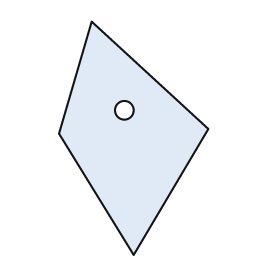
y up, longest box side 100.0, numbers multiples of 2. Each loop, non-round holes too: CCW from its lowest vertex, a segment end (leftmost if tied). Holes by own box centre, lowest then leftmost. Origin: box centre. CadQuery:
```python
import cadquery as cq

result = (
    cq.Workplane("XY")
    .moveTo(0.0, -50.0)
    .lineTo(32.0, 4.0)
    .lineTo(-18.0, 50.0)
    .lineTo(-32.0, 2.0)
    .close()
    .moveTo(-4.0, 12.0)
    .circle(4.0)
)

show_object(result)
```